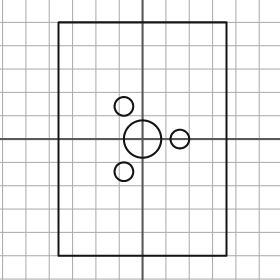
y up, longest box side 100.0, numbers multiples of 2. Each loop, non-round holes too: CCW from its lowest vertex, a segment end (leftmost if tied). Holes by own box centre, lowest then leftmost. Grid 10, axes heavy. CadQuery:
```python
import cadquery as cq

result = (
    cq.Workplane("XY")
    .moveTo(-36.0, -50.0)
    .lineTo(36.0, -50.0)
    .lineTo(36.0, 50.0)
    .lineTo(-36.0, 50.0)
    .close()
    .moveTo(-8.0, -14.0)
    .circle(4.0)
    .moveTo(0.0, 0.0)
    .circle(8.0)
    .moveTo(16.0, 0.0)
    .circle(4.0)
    .moveTo(-8.0, 14.0)
    .circle(4.0)
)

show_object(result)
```